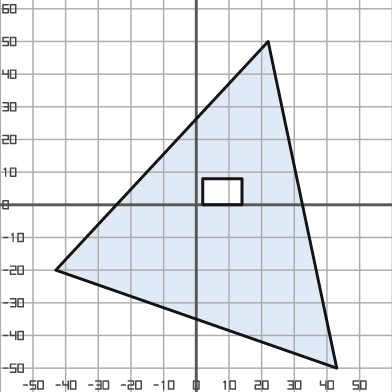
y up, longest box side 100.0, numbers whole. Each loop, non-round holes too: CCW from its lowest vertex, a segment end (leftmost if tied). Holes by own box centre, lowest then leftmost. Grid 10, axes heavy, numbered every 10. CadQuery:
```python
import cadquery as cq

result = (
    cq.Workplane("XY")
    .moveTo(43.0, -50.0)
    .lineTo(22.0, 50.0)
    .lineTo(-43.0, -20.0)
    .close()
    .moveTo(2.0, 0.0)
    .lineTo(14.0, 0.0)
    .lineTo(14.0, 8.0)
    .lineTo(2.0, 8.0)
    .close()
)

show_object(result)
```